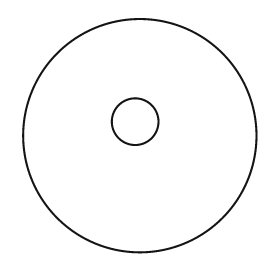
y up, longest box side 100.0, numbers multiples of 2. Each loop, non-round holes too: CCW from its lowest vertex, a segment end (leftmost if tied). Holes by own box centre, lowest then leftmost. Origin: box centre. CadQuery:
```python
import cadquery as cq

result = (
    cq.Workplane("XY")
    .moveTo(0.0, 0.0)
    .circle(50.0)
    .moveTo(-2.0, 6.0)
    .circle(10.0)
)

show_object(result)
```